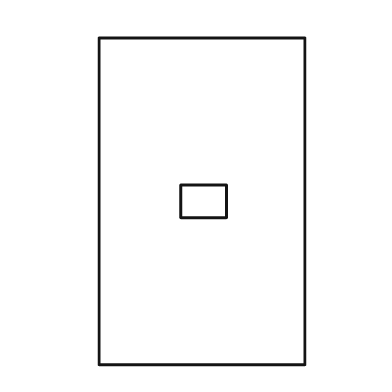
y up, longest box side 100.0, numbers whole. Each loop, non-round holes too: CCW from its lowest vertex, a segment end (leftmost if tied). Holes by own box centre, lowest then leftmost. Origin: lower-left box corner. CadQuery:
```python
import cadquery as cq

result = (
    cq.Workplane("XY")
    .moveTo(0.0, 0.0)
    .lineTo(63.0, 0.0)
    .lineTo(63.0, 100.0)
    .lineTo(0.0, 100.0)
    .close()
    .moveTo(25.0, 45.0)
    .lineTo(39.0, 45.0)
    .lineTo(39.0, 55.0)
    .lineTo(25.0, 55.0)
    .close()
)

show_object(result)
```